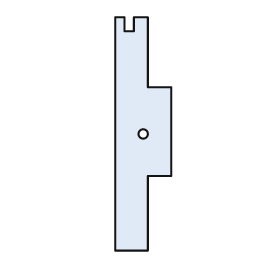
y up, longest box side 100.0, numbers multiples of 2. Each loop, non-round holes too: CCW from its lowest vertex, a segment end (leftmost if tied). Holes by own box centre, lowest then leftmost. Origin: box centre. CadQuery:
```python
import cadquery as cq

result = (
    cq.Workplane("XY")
    .moveTo(-12.0, -50.0)
    .lineTo(2.0, -50.0)
    .lineTo(2.0, -18.0)
    .lineTo(12.0, -18.0)
    .lineTo(12.0, 20.0)
    .lineTo(2.0, 20.0)
    .lineTo(2.0, 50.0)
    .lineTo(-4.0, 50.0)
    .lineTo(-4.0, 44.0)
    .lineTo(-8.0, 44.0)
    .lineTo(-8.0, 50.0)
    .lineTo(-12.0, 50.0)
    .close()
    .moveTo(0.0, 0.0)
    .circle(2.0)
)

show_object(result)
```